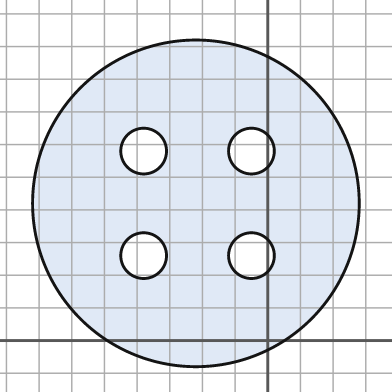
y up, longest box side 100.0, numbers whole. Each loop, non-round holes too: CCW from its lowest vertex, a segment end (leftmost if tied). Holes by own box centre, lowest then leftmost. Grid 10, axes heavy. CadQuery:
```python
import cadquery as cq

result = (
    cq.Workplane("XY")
    .moveTo(-22.0, 42.0)
    .circle(50.0)
    .moveTo(-38.0, 26.0)
    .circle(7.0)
    .moveTo(-5.0, 26.0)
    .circle(7.0)
    .moveTo(-38.0, 58.0)
    .circle(7.0)
    .moveTo(-5.0, 58.0)
    .circle(7.0)
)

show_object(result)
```